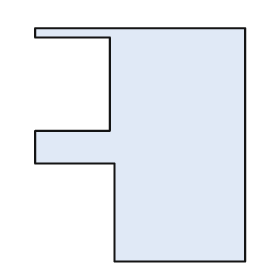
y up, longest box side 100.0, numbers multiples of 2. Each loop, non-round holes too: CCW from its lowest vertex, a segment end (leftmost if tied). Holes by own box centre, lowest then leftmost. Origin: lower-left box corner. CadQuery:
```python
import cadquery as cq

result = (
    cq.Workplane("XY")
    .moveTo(34.0, 0.0)
    .lineTo(90.0, 0.0)
    .lineTo(90.0, 100.0)
    .lineTo(0.0, 100.0)
    .lineTo(0.0, 96.0)
    .lineTo(32.0, 96.0)
    .lineTo(32.0, 56.0)
    .lineTo(0.0, 56.0)
    .lineTo(0.0, 42.0)
    .lineTo(34.0, 42.0)
    .close()
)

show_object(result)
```